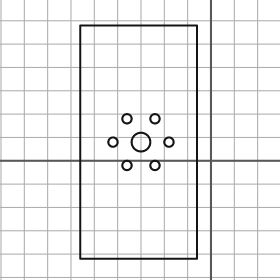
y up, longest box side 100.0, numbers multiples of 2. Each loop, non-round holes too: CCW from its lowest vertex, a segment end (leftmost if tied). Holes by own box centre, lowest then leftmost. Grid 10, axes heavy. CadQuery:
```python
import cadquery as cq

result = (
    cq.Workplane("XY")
    .moveTo(-56.0, -42.0)
    .lineTo(-6.0, -42.0)
    .lineTo(-6.0, 58.0)
    .lineTo(-56.0, 58.0)
    .close()
    .moveTo(-36.0, -2.0)
    .circle(2.0)
    .moveTo(-24.0, -2.0)
    .circle(2.0)
    .moveTo(-42.0, 8.0)
    .circle(2.0)
    .moveTo(-30.0, 8.0)
    .circle(4.0)
    .moveTo(-18.0, 8.0)
    .circle(2.0)
    .moveTo(-36.0, 18.0)
    .circle(2.0)
    .moveTo(-24.0, 18.0)
    .circle(2.0)
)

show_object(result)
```